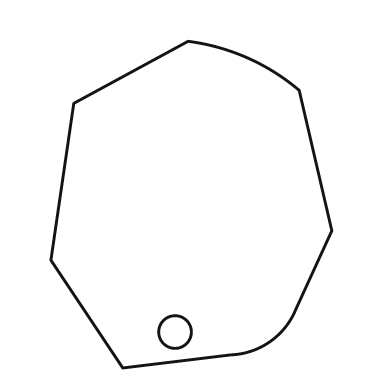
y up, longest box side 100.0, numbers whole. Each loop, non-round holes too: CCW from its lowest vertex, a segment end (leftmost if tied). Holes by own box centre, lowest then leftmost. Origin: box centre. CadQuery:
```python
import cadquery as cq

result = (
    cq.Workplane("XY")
    .moveTo(-21.0, -50.0)
    .lineTo(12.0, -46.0)
    .threePointArc((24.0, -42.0), (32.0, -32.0))
    .lineTo(43.0, -8.0)
    .lineTo(33.0, 35.0)
    .threePointArc((17.0, 45.0), (-1.0, 50.0))
    .lineTo(-36.0, 31.0)
    .lineTo(-43.0, -17.0)
    .close()
    .moveTo(-5.0, -39.0)
    .circle(5.0)
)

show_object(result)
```